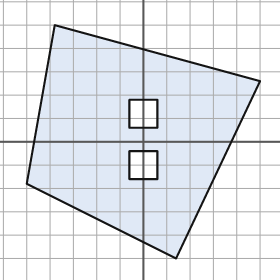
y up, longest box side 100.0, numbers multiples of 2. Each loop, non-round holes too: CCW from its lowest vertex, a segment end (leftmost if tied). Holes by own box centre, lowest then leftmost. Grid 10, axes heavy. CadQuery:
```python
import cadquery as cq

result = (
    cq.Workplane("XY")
    .moveTo(14.0, -50.0)
    .lineTo(50.0, 26.0)
    .lineTo(-38.0, 50.0)
    .lineTo(-50.0, -18.0)
    .close()
    .moveTo(-6.0, -16.0)
    .lineTo(6.0, -16.0)
    .lineTo(6.0, -4.0)
    .lineTo(-6.0, -4.0)
    .close()
    .moveTo(-6.0, 6.0)
    .lineTo(6.0, 6.0)
    .lineTo(6.0, 18.0)
    .lineTo(-6.0, 18.0)
    .close()
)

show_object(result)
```